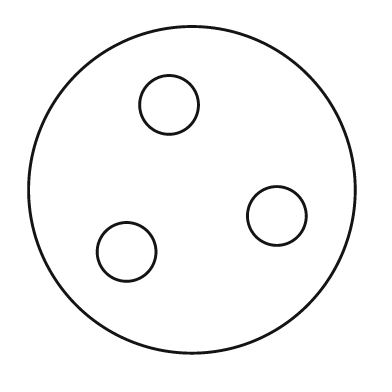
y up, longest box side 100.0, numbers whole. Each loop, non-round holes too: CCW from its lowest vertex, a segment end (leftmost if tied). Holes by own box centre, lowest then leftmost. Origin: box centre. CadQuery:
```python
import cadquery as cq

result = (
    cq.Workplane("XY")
    .moveTo(0.0, 0.0)
    .circle(50.0)
    .moveTo(-20.0, -19.0)
    .circle(9.0)
    .moveTo(26.0, -8.0)
    .circle(9.0)
    .moveTo(-7.0, 26.0)
    .circle(9.0)
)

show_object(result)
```